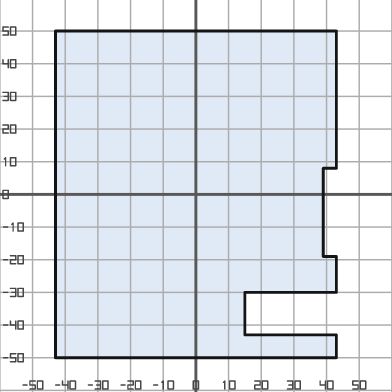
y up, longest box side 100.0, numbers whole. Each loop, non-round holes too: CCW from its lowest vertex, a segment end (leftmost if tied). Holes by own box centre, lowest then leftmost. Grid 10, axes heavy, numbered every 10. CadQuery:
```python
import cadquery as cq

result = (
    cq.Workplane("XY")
    .moveTo(-43.0, -50.0)
    .lineTo(43.0, -50.0)
    .lineTo(43.0, -43.0)
    .lineTo(15.0, -43.0)
    .lineTo(15.0, -30.0)
    .lineTo(43.0, -30.0)
    .lineTo(43.0, -19.0)
    .lineTo(39.0, -19.0)
    .lineTo(39.0, 8.0)
    .lineTo(43.0, 8.0)
    .lineTo(43.0, 50.0)
    .lineTo(-43.0, 50.0)
    .close()
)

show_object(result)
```